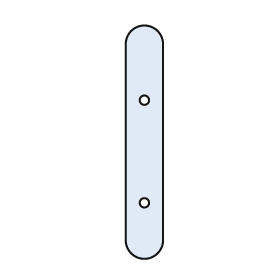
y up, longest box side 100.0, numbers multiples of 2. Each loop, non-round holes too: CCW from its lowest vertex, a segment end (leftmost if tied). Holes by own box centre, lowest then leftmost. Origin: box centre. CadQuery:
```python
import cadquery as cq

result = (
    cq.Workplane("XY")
    .moveTo(-8.0, -42.0)
    .threePointArc((0.0, -50.0), (8.0, -42.0))
    .lineTo(8.0, 42.0)
    .threePointArc((0.0, 50.0), (-8.0, 42.0))
    .close()
    .moveTo(0.0, -26.0)
    .circle(2.0)
    .moveTo(0.0, 18.0)
    .circle(2.0)
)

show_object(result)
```